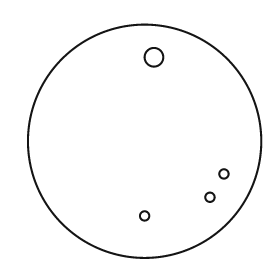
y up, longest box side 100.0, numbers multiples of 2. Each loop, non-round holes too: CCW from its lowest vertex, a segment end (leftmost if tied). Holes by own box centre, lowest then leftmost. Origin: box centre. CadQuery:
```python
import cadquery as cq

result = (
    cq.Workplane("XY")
    .moveTo(0.0, 0.0)
    .circle(50.0)
    .moveTo(0.0, -32.0)
    .circle(2.0)
    .moveTo(28.0, -24.0)
    .circle(2.0)
    .moveTo(34.0, -14.0)
    .circle(2.0)
    .moveTo(4.0, 36.0)
    .circle(4.0)
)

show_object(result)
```